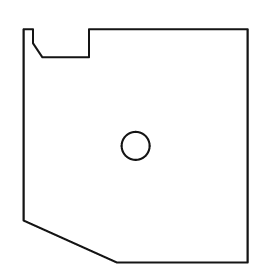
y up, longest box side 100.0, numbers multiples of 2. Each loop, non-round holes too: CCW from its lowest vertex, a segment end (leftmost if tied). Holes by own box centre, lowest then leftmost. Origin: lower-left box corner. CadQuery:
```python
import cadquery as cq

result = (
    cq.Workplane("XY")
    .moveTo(40.0, 0.0)
    .lineTo(96.0, 0.0)
    .lineTo(96.0, 100.0)
    .lineTo(28.0, 100.0)
    .lineTo(28.0, 88.0)
    .lineTo(8.0, 88.0)
    .lineTo(4.0, 94.0)
    .lineTo(4.0, 100.0)
    .lineTo(0.0, 100.0)
    .lineTo(0.0, 18.0)
    .close()
    .moveTo(48.0, 50.0)
    .circle(6.0)
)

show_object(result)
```